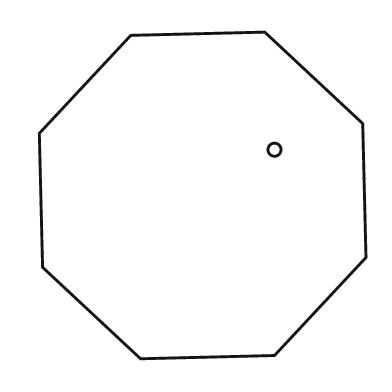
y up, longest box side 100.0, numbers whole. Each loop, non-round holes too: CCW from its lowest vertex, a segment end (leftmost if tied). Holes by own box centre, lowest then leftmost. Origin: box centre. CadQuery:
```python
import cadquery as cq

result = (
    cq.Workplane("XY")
    .moveTo(-19.0, -50.0)
    .lineTo(22.0, -49.0)
    .lineTo(50.0, -19.0)
    .lineTo(49.0, 22.0)
    .lineTo(19.0, 50.0)
    .lineTo(-22.0, 49.0)
    .lineTo(-50.0, 19.0)
    .lineTo(-49.0, -22.0)
    .close()
    .moveTo(22.0, 14.0)
    .circle(2.0)
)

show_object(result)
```